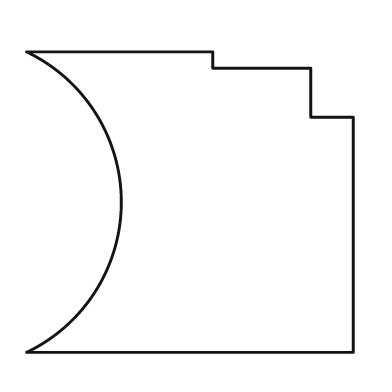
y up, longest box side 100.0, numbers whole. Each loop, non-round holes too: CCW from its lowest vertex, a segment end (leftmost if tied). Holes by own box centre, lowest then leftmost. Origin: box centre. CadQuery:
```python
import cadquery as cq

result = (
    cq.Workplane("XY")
    .moveTo(-50.0, -46.0)
    .lineTo(50.0, -46.0)
    .lineTo(50.0, 26.0)
    .lineTo(37.0, 26.0)
    .lineTo(37.0, 41.0)
    .lineTo(7.0, 41.0)
    .lineTo(7.0, 46.0)
    .lineTo(-50.0, 46.0)
    .threePointArc((-21.0, 0.0), (-50.0, -46.0))
    .close()
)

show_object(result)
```